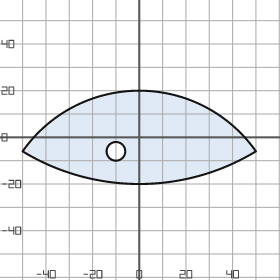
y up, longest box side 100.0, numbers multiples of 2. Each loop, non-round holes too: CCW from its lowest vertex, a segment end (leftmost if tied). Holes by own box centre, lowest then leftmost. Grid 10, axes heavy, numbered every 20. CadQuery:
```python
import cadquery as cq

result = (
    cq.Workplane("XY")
    .moveTo(-50.0, -6.0)
    .threePointArc((0.0, -20.0), (50.0, -6.0))
    .threePointArc((0.0, 20.0), (-50.0, -6.0))
    .close()
    .moveTo(-10.0, -6.0)
    .circle(4.0)
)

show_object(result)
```